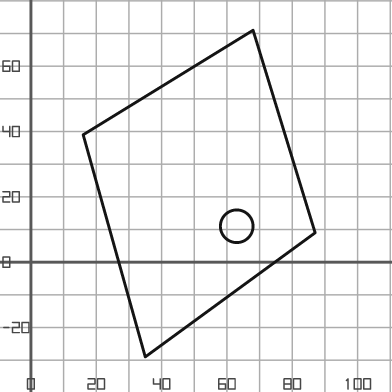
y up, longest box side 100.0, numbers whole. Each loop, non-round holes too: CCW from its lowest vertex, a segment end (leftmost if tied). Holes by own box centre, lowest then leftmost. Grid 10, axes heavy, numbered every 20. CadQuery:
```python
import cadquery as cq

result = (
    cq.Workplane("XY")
    .moveTo(35.0, -29.0)
    .lineTo(87.0, 9.0)
    .lineTo(68.0, 71.0)
    .lineTo(16.0, 39.0)
    .close()
    .moveTo(63.0, 11.0)
    .circle(5.0)
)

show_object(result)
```